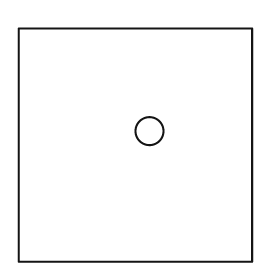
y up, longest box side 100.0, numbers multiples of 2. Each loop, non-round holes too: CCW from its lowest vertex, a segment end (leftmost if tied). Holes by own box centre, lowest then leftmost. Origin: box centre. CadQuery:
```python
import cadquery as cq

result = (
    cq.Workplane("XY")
    .moveTo(-50.0, -50.0)
    .lineTo(50.0, -50.0)
    .lineTo(50.0, 50.0)
    .lineTo(-50.0, 50.0)
    .close()
    .moveTo(6.0, 6.0)
    .circle(6.0)
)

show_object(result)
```